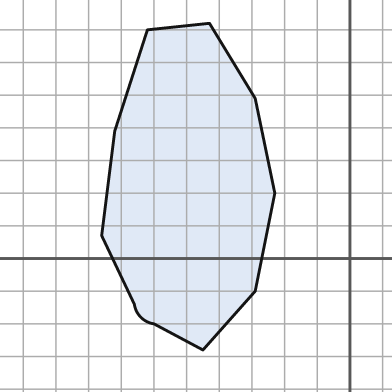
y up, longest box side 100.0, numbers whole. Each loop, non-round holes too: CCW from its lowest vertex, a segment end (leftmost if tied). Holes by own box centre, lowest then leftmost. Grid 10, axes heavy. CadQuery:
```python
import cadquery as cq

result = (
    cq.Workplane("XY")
    .moveTo(-45.0, -28.0)
    .lineTo(-29.0, -10.0)
    .lineTo(-23.0, 20.0)
    .lineTo(-29.0, 49.0)
    .lineTo(-43.0, 72.0)
    .lineTo(-62.0, 70.0)
    .lineTo(-72.0, 39.0)
    .lineTo(-76.0, 7.0)
    .lineTo(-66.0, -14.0)
    .threePointArc((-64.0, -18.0), (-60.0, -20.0))
    .close()
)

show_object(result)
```